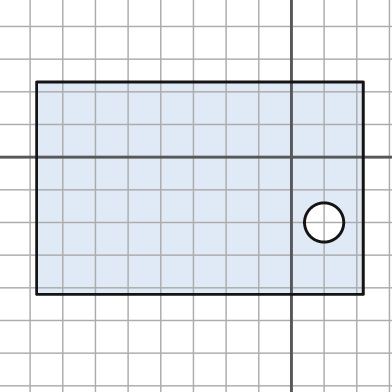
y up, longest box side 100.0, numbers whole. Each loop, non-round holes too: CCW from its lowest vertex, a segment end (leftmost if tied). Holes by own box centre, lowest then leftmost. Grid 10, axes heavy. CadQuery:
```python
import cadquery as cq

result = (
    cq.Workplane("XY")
    .moveTo(-78.0, -42.0)
    .lineTo(22.0, -42.0)
    .lineTo(22.0, 23.0)
    .lineTo(-78.0, 23.0)
    .close()
    .moveTo(10.0, -20.0)
    .circle(6.0)
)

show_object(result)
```